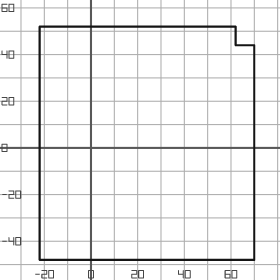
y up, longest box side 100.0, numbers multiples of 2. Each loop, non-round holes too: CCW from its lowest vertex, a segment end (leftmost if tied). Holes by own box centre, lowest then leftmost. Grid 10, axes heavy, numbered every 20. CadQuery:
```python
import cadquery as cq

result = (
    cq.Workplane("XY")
    .moveTo(-22.0, -48.0)
    .lineTo(70.0, -48.0)
    .lineTo(70.0, 44.0)
    .lineTo(62.0, 44.0)
    .lineTo(62.0, 52.0)
    .lineTo(-22.0, 52.0)
    .close()
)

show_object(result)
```